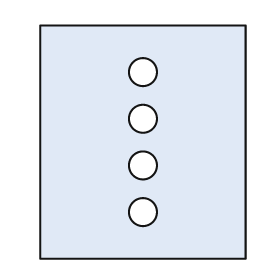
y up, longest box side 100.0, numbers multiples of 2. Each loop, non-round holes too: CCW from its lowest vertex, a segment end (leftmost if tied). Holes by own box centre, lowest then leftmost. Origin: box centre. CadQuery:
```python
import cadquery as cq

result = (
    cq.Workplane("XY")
    .moveTo(-44.0, -50.0)
    .lineTo(44.0, -50.0)
    .lineTo(44.0, 50.0)
    .lineTo(-44.0, 50.0)
    .close()
    .moveTo(0.0, -30.0)
    .circle(6.0)
    .moveTo(0.0, -10.0)
    .circle(6.0)
    .moveTo(0.0, 10.0)
    .circle(6.0)
    .moveTo(0.0, 30.0)
    .circle(6.0)
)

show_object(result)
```